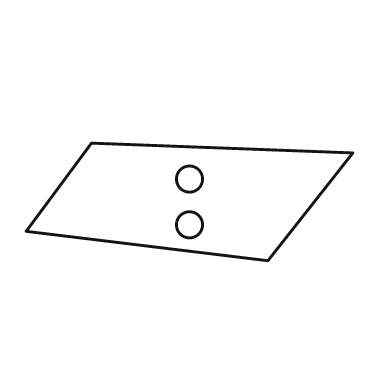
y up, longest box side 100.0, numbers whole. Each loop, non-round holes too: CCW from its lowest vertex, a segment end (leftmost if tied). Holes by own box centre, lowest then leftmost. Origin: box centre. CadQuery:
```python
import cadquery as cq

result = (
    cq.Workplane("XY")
    .moveTo(24.0, -18.0)
    .lineTo(50.0, 15.0)
    .lineTo(-30.0, 18.0)
    .lineTo(-50.0, -9.0)
    .close()
    .moveTo(0.0, -7.0)
    .circle(4.0)
    .moveTo(0.0, 7.0)
    .circle(4.0)
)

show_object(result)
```